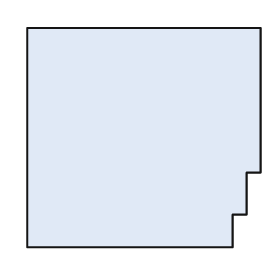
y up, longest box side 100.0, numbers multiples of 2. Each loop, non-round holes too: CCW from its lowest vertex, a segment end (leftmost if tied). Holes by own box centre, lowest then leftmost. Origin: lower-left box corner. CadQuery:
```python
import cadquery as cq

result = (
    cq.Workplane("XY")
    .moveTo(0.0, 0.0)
    .lineTo(88.0, 0.0)
    .lineTo(88.0, 14.0)
    .lineTo(94.0, 14.0)
    .lineTo(94.0, 32.0)
    .lineTo(100.0, 32.0)
    .lineTo(100.0, 94.0)
    .lineTo(0.0, 94.0)
    .close()
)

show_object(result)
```